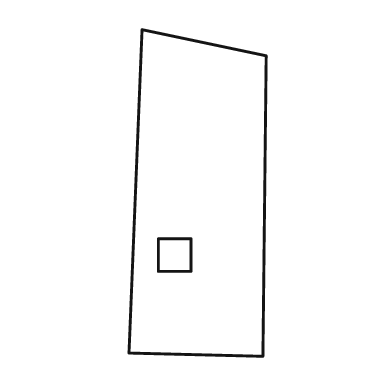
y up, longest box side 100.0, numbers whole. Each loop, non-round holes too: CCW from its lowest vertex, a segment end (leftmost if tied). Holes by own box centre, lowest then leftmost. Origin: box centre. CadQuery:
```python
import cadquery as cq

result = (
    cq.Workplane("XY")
    .moveTo(20.0, -50.0)
    .lineTo(21.0, 42.0)
    .lineTo(-17.0, 50.0)
    .lineTo(-21.0, -49.0)
    .close()
    .moveTo(-12.0, -24.0)
    .lineTo(-2.0, -24.0)
    .lineTo(-2.0, -14.0)
    .lineTo(-12.0, -14.0)
    .close()
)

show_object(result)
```